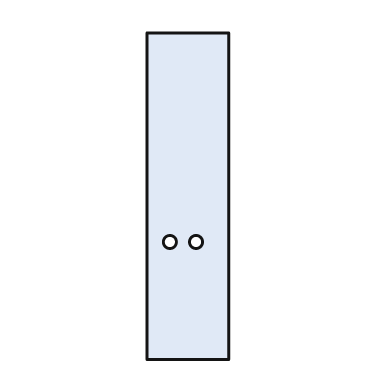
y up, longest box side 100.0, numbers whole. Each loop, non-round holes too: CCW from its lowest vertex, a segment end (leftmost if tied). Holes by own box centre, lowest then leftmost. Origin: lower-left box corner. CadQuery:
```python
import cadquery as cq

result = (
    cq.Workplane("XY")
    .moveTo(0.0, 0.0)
    .lineTo(25.0, 0.0)
    .lineTo(25.0, 100.0)
    .lineTo(0.0, 100.0)
    .close()
    .moveTo(7.0, 36.0)
    .circle(2.0)
    .moveTo(15.0, 36.0)
    .circle(2.0)
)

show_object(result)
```